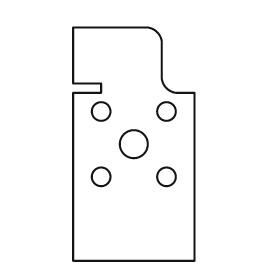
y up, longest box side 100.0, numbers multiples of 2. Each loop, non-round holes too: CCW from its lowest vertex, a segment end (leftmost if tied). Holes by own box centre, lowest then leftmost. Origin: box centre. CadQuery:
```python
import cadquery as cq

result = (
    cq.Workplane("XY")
    .moveTo(-26.0, -50.0)
    .lineTo(26.0, -50.0)
    .lineTo(26.0, 22.0)
    .lineTo(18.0, 22.0)
    .threePointArc((14.0, 24.0), (12.0, 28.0))
    .lineTo(12.0, 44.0)
    .threePointArc((10.0, 48.0), (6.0, 50.0))
    .lineTo(-26.0, 50.0)
    .lineTo(-26.0, 26.0)
    .lineTo(-14.0, 26.0)
    .lineTo(-14.0, 22.0)
    .lineTo(-26.0, 22.0)
    .close()
    .moveTo(-14.0, -14.0)
    .circle(4.0)
    .moveTo(14.0, -14.0)
    .circle(4.0)
    .moveTo(0.0, 0.0)
    .circle(6.0)
    .moveTo(-14.0, 14.0)
    .circle(4.0)
    .moveTo(14.0, 14.0)
    .circle(4.0)
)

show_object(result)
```